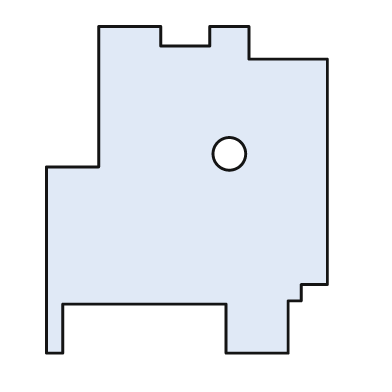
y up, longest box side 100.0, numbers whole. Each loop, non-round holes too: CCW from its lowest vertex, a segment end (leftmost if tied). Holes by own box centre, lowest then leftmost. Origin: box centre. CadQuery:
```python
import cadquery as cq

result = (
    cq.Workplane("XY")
    .moveTo(-43.0, -50.0)
    .lineTo(-38.0, -50.0)
    .lineTo(-38.0, -35.0)
    .lineTo(12.0, -35.0)
    .lineTo(12.0, -50.0)
    .lineTo(31.0, -50.0)
    .lineTo(31.0, -34.0)
    .lineTo(35.0, -34.0)
    .lineTo(35.0, -29.0)
    .lineTo(43.0, -29.0)
    .lineTo(43.0, 40.0)
    .lineTo(19.0, 40.0)
    .lineTo(19.0, 50.0)
    .lineTo(7.0, 50.0)
    .lineTo(7.0, 44.0)
    .lineTo(-8.0, 44.0)
    .lineTo(-8.0, 50.0)
    .lineTo(-27.0, 50.0)
    .lineTo(-27.0, 7.0)
    .lineTo(-43.0, 7.0)
    .close()
    .moveTo(13.0, 11.0)
    .circle(5.0)
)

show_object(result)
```